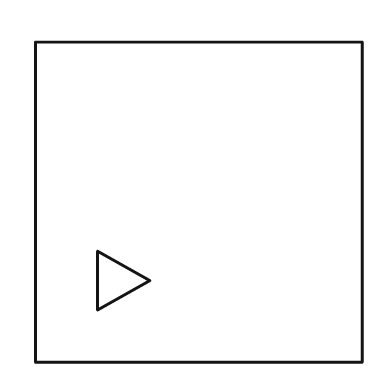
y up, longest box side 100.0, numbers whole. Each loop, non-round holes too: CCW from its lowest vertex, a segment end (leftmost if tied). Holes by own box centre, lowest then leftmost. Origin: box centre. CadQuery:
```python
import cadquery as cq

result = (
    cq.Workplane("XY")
    .moveTo(-50.0, -49.0)
    .lineTo(50.0, -49.0)
    .lineTo(50.0, 49.0)
    .lineTo(-50.0, 49.0)
    .close()
    .moveTo(-31.0, -33.0)
    .lineTo(-15.0, -24.0)
    .lineTo(-31.0, -15.0)
    .close()
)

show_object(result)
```